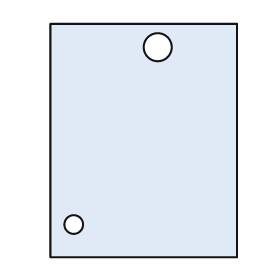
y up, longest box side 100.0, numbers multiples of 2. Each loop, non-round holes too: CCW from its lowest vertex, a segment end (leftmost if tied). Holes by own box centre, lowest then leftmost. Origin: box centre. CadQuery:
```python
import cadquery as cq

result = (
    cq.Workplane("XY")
    .moveTo(-40.0, -50.0)
    .lineTo(40.0, -50.0)
    .lineTo(40.0, 50.0)
    .lineTo(-40.0, 50.0)
    .close()
    .moveTo(-30.0, -36.0)
    .circle(4.0)
    .moveTo(6.0, 40.0)
    .circle(6.0)
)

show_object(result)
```